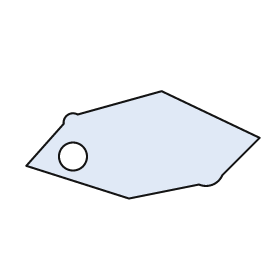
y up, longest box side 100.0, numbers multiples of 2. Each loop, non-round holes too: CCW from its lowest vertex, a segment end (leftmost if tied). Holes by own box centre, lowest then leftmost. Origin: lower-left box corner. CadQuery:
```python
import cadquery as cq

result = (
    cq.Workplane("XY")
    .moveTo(44.0, 0.0)
    .lineTo(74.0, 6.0)
    .threePointArc((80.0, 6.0), (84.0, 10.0))
    .lineTo(100.0, 26.0)
    .lineTo(58.0, 46.0)
    .lineTo(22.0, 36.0)
    .threePointArc((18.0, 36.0), (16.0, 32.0))
    .lineTo(0.0, 14.0)
    .close()
    .moveTo(20.0, 18.0)
    .circle(6.0)
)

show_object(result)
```